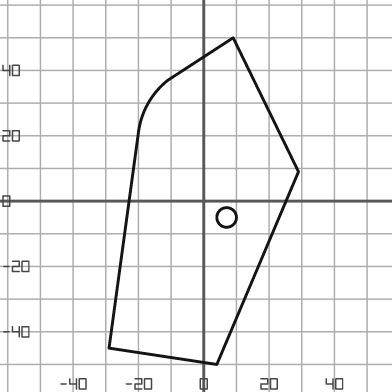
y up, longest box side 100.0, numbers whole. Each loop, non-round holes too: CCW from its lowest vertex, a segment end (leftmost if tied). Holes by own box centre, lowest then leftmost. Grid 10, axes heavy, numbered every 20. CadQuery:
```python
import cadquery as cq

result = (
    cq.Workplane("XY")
    .moveTo(4.0, -50.0)
    .lineTo(29.0, 9.0)
    .lineTo(9.0, 50.0)
    .lineTo(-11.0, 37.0)
    .threePointArc((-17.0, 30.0), (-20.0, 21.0))
    .lineTo(-29.0, -45.0)
    .close()
    .moveTo(7.0, -5.0)
    .circle(3.0)
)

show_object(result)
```